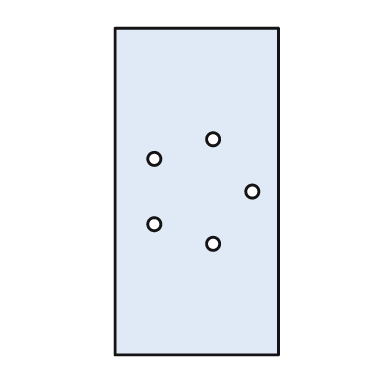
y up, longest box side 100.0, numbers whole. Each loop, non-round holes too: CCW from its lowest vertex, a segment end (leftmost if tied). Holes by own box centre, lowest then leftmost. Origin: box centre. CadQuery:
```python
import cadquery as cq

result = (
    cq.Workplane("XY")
    .moveTo(-25.0, -50.0)
    .lineTo(25.0, -50.0)
    .lineTo(25.0, 50.0)
    .lineTo(-25.0, 50.0)
    .close()
    .moveTo(5.0, -16.0)
    .circle(2.0)
    .moveTo(-13.0, -10.0)
    .circle(2.0)
    .moveTo(17.0, 0.0)
    .circle(2.0)
    .moveTo(-13.0, 10.0)
    .circle(2.0)
    .moveTo(5.0, 16.0)
    .circle(2.0)
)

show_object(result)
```